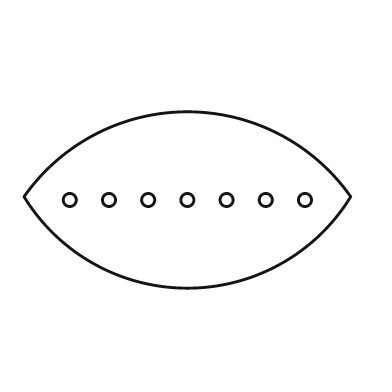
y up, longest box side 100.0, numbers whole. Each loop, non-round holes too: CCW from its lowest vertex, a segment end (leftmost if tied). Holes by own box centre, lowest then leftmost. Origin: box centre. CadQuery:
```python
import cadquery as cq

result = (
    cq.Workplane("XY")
    .moveTo(-50.0, 1.0)
    .threePointArc((0.0, -27.0), (50.0, 1.0))
    .threePointArc((0.0, 27.0), (-50.0, 1.0))
    .close()
    .moveTo(-36.0, 0.0)
    .circle(2.0)
    .moveTo(-24.0, 0.0)
    .circle(2.0)
    .moveTo(-12.0, 0.0)
    .circle(2.0)
    .moveTo(0.0, 0.0)
    .circle(2.0)
    .moveTo(12.0, 0.0)
    .circle(2.0)
    .moveTo(24.0, 0.0)
    .circle(2.0)
    .moveTo(36.0, 0.0)
    .circle(2.0)
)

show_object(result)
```